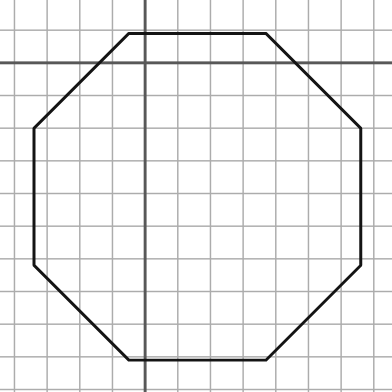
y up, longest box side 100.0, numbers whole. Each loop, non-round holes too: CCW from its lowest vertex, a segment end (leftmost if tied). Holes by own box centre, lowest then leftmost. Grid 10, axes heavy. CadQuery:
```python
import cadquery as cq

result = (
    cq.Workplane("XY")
    .moveTo(-5.0, -91.0)
    .lineTo(37.0, -91.0)
    .lineTo(66.0, -62.0)
    .lineTo(66.0, -20.0)
    .lineTo(37.0, 9.0)
    .lineTo(-5.0, 9.0)
    .lineTo(-34.0, -20.0)
    .lineTo(-34.0, -62.0)
    .close()
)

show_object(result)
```